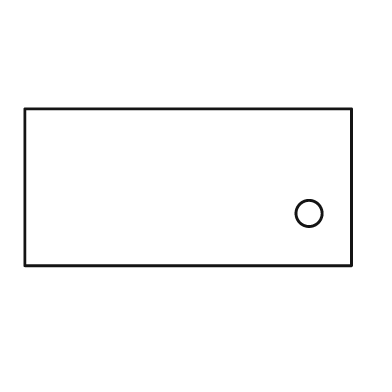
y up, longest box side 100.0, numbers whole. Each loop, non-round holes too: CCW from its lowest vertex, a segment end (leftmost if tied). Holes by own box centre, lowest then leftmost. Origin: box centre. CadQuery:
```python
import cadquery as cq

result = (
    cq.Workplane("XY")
    .moveTo(-50.0, -24.0)
    .lineTo(50.0, -24.0)
    .lineTo(50.0, 24.0)
    .lineTo(-50.0, 24.0)
    .close()
    .moveTo(37.0, -8.0)
    .circle(4.0)
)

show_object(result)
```